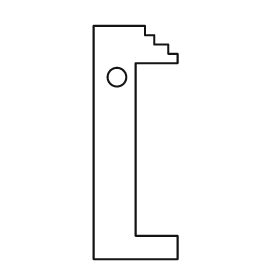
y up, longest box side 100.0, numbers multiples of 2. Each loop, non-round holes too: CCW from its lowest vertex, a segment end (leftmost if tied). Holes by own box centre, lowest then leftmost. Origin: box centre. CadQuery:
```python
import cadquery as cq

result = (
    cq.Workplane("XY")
    .moveTo(-18.0, -50.0)
    .lineTo(18.0, -50.0)
    .lineTo(18.0, -40.0)
    .lineTo(0.0, -40.0)
    .lineTo(0.0, 34.0)
    .lineTo(18.0, 34.0)
    .lineTo(18.0, 38.0)
    .lineTo(14.0, 38.0)
    .lineTo(14.0, 42.0)
    .lineTo(8.0, 42.0)
    .lineTo(8.0, 46.0)
    .lineTo(4.0, 46.0)
    .lineTo(4.0, 50.0)
    .lineTo(-18.0, 50.0)
    .close()
    .moveTo(-8.0, 28.0)
    .circle(4.0)
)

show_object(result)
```